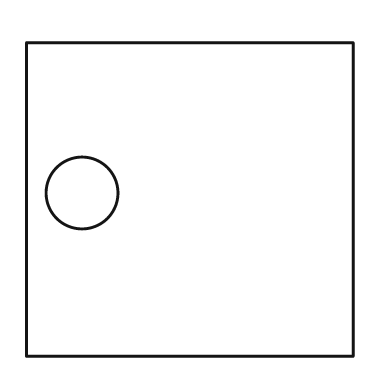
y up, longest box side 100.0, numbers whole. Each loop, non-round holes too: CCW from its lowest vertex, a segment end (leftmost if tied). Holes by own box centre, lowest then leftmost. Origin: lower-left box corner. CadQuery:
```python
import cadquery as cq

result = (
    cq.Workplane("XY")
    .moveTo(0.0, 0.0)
    .lineTo(100.0, 0.0)
    .lineTo(100.0, 96.0)
    .lineTo(0.0, 96.0)
    .close()
    .moveTo(17.0, 50.0)
    .circle(11.0)
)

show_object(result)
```